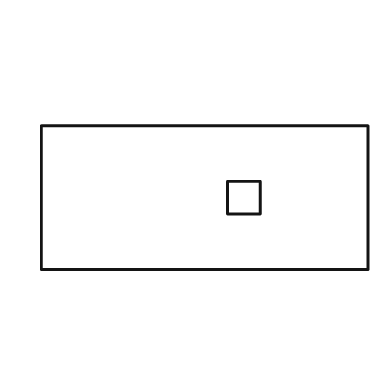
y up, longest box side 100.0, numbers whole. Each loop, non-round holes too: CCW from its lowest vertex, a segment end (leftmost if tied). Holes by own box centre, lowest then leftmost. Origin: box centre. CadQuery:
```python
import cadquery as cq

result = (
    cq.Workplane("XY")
    .moveTo(-50.0, -22.0)
    .lineTo(50.0, -22.0)
    .lineTo(50.0, 22.0)
    .lineTo(-50.0, 22.0)
    .close()
    .moveTo(7.0, -5.0)
    .lineTo(17.0, -5.0)
    .lineTo(17.0, 5.0)
    .lineTo(7.0, 5.0)
    .close()
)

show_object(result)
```